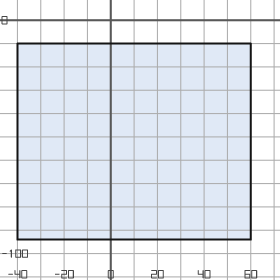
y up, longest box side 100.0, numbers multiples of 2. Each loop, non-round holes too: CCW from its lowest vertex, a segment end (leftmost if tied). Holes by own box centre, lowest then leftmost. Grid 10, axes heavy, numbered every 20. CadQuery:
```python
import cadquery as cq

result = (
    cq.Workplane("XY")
    .moveTo(-40.0, -94.0)
    .lineTo(60.0, -94.0)
    .lineTo(60.0, -10.0)
    .lineTo(-40.0, -10.0)
    .close()
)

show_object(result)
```